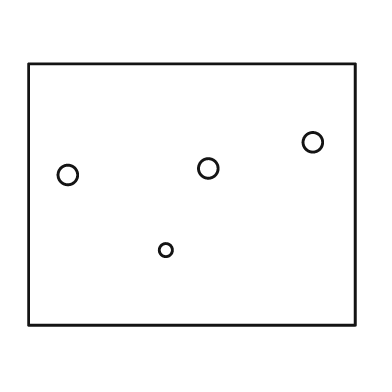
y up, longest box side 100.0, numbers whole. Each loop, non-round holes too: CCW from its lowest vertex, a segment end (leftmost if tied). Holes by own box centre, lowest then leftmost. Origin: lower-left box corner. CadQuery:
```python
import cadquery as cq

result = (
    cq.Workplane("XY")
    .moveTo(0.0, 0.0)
    .lineTo(100.0, 0.0)
    .lineTo(100.0, 80.0)
    .lineTo(0.0, 80.0)
    .close()
    .moveTo(42.0, 23.0)
    .circle(2.0)
    .moveTo(12.0, 46.0)
    .circle(3.0)
    .moveTo(55.0, 48.0)
    .circle(3.0)
    .moveTo(87.0, 56.0)
    .circle(3.0)
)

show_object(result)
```